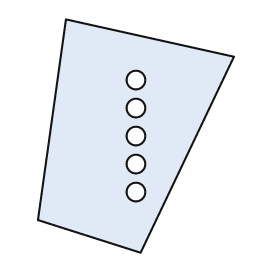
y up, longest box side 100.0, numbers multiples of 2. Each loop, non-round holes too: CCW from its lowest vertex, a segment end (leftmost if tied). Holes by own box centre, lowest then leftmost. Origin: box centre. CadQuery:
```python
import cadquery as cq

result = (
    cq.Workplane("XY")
    .moveTo(2.0, -50.0)
    .lineTo(42.0, 34.0)
    .lineTo(-30.0, 50.0)
    .lineTo(-42.0, -36.0)
    .close()
    .moveTo(0.0, -24.0)
    .circle(4.0)
    .moveTo(0.0, -12.0)
    .circle(4.0)
    .moveTo(0.0, 0.0)
    .circle(4.0)
    .moveTo(0.0, 12.0)
    .circle(4.0)
    .moveTo(0.0, 24.0)
    .circle(4.0)
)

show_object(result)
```